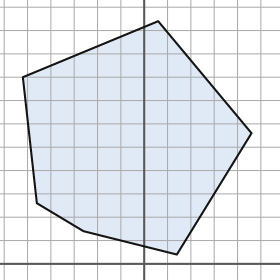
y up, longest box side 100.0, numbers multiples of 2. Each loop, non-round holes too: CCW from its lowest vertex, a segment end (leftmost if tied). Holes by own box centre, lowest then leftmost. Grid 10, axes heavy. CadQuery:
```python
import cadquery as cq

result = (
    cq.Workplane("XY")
    .moveTo(14.0, 4.0)
    .lineTo(46.0, 56.0)
    .lineTo(6.0, 104.0)
    .lineTo(-52.0, 80.0)
    .lineTo(-46.0, 26.0)
    .lineTo(-26.0, 14.0)
    .close()
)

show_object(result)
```